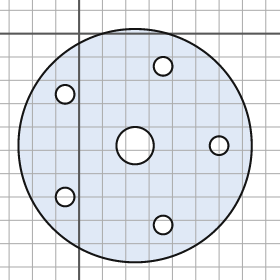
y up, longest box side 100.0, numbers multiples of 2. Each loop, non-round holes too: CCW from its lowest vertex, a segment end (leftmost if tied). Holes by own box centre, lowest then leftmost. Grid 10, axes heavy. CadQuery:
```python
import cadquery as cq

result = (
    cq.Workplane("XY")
    .moveTo(24.0, -48.0)
    .circle(50.0)
    .moveTo(36.0, -82.0)
    .circle(4.0)
    .moveTo(-6.0, -70.0)
    .circle(4.0)
    .moveTo(24.0, -48.0)
    .circle(8.0)
    .moveTo(60.0, -48.0)
    .circle(4.0)
    .moveTo(-6.0, -26.0)
    .circle(4.0)
    .moveTo(36.0, -14.0)
    .circle(4.0)
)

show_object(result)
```